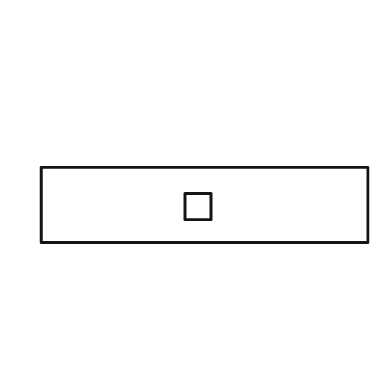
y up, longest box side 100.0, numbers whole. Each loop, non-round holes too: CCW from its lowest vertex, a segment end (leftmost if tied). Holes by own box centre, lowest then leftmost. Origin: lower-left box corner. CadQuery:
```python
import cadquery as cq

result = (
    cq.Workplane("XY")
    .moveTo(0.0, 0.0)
    .lineTo(100.0, 0.0)
    .lineTo(100.0, 23.0)
    .lineTo(0.0, 23.0)
    .close()
    .moveTo(44.0, 7.0)
    .lineTo(52.0, 7.0)
    .lineTo(52.0, 15.0)
    .lineTo(44.0, 15.0)
    .close()
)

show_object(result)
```